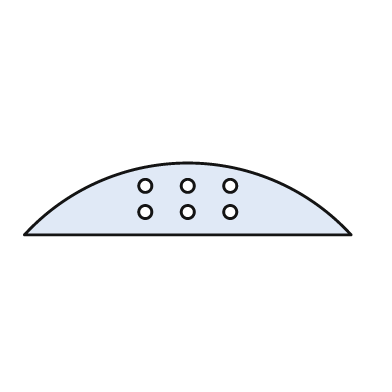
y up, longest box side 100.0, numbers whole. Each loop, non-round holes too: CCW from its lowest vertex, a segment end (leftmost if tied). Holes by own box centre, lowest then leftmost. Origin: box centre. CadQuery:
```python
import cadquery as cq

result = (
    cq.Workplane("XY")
    .moveTo(-50.0, -11.0)
    .lineTo(50.0, -11.0)
    .threePointArc((0.0, 11.0), (-50.0, -11.0))
    .close()
    .moveTo(-13.0, -4.0)
    .circle(2.0)
    .moveTo(0.0, -4.0)
    .circle(2.0)
    .moveTo(13.0, -4.0)
    .circle(2.0)
    .moveTo(-13.0, 4.0)
    .circle(2.0)
    .moveTo(0.0, 4.0)
    .circle(2.0)
    .moveTo(13.0, 4.0)
    .circle(2.0)
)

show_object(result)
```